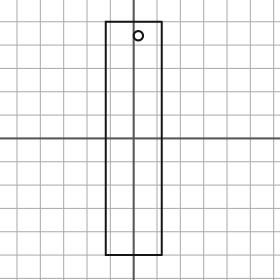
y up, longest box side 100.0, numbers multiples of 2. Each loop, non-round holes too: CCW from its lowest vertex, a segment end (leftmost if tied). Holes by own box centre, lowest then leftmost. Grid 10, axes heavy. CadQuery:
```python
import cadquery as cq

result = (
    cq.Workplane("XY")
    .moveTo(-12.0, -50.0)
    .lineTo(12.0, -50.0)
    .lineTo(12.0, 50.0)
    .lineTo(-12.0, 50.0)
    .close()
    .moveTo(2.0, 44.0)
    .circle(2.0)
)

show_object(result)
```